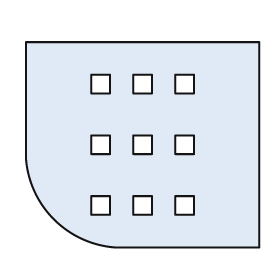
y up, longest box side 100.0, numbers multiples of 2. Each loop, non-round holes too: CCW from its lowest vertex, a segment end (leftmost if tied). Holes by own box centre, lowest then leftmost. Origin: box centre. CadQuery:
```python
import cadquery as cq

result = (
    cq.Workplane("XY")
    .moveTo(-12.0, -44.0)
    .lineTo(50.0, -44.0)
    .lineTo(50.0, 44.0)
    .lineTo(-50.0, 44.0)
    .lineTo(-50.0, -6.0)
    .threePointArc((-38.0, -32.0), (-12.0, -44.0))
    .close()
    .moveTo(-22.0, -30.0)
    .lineTo(-14.0, -30.0)
    .lineTo(-14.0, -22.0)
    .lineTo(-22.0, -22.0)
    .close()
    .moveTo(-4.0, -30.0)
    .lineTo(4.0, -30.0)
    .lineTo(4.0, -22.0)
    .lineTo(-4.0, -22.0)
    .close()
    .moveTo(14.0, -30.0)
    .lineTo(22.0, -30.0)
    .lineTo(22.0, -22.0)
    .lineTo(14.0, -22.0)
    .close()
    .moveTo(-22.0, -4.0)
    .lineTo(-14.0, -4.0)
    .lineTo(-14.0, 4.0)
    .lineTo(-22.0, 4.0)
    .close()
    .moveTo(-4.0, -4.0)
    .lineTo(4.0, -4.0)
    .lineTo(4.0, 4.0)
    .lineTo(-4.0, 4.0)
    .close()
    .moveTo(14.0, -4.0)
    .lineTo(22.0, -4.0)
    .lineTo(22.0, 4.0)
    .lineTo(14.0, 4.0)
    .close()
    .moveTo(-22.0, 22.0)
    .lineTo(-14.0, 22.0)
    .lineTo(-14.0, 30.0)
    .lineTo(-22.0, 30.0)
    .close()
    .moveTo(-4.0, 22.0)
    .lineTo(4.0, 22.0)
    .lineTo(4.0, 30.0)
    .lineTo(-4.0, 30.0)
    .close()
    .moveTo(14.0, 22.0)
    .lineTo(22.0, 22.0)
    .lineTo(22.0, 30.0)
    .lineTo(14.0, 30.0)
    .close()
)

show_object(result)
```